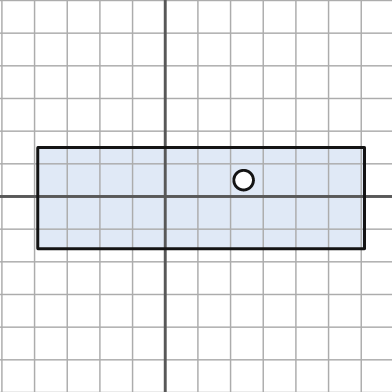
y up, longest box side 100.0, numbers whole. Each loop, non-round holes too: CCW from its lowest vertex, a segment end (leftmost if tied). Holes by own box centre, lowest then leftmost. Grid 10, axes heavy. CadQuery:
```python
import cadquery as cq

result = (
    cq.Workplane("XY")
    .moveTo(-39.0, -16.0)
    .lineTo(61.0, -16.0)
    .lineTo(61.0, 15.0)
    .lineTo(-39.0, 15.0)
    .close()
    .moveTo(24.0, 5.0)
    .circle(3.0)
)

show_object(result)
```